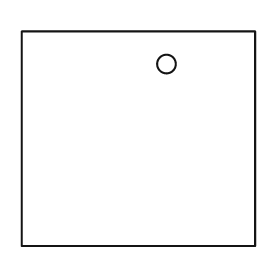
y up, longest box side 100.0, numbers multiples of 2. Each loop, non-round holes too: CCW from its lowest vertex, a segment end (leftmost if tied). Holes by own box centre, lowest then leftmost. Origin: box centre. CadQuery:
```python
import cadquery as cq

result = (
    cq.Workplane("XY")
    .moveTo(-50.0, -46.0)
    .lineTo(50.0, -46.0)
    .lineTo(50.0, 46.0)
    .lineTo(-50.0, 46.0)
    .close()
    .moveTo(12.0, 32.0)
    .circle(4.0)
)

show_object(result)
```